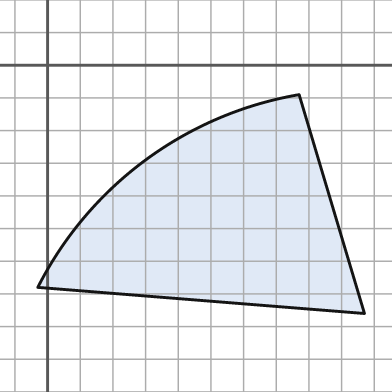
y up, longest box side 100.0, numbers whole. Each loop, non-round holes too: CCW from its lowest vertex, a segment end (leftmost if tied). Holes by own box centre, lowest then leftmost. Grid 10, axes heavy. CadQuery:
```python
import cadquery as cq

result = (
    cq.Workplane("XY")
    .moveTo(97.0, -76.0)
    .lineTo(77.0, -9.0)
    .threePointArc((30.0, -29.0), (-3.0, -68.0))
    .close()
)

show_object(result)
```